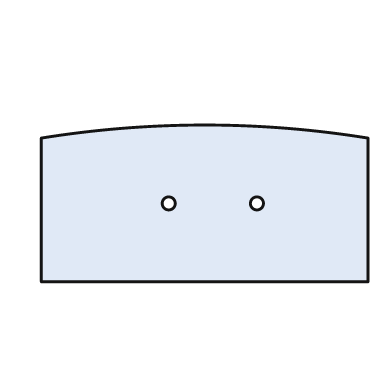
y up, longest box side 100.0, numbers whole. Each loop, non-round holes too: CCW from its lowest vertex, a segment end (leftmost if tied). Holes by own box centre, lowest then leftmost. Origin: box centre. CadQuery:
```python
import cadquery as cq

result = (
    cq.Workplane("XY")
    .moveTo(-50.0, -24.0)
    .lineTo(50.0, -24.0)
    .lineTo(50.0, 20.0)
    .threePointArc((0.0, 24.0), (-50.0, 20.0))
    .close()
    .moveTo(-11.0, 0.0)
    .circle(2.0)
    .moveTo(16.0, 0.0)
    .circle(2.0)
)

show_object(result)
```